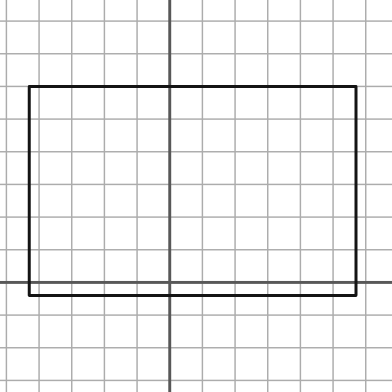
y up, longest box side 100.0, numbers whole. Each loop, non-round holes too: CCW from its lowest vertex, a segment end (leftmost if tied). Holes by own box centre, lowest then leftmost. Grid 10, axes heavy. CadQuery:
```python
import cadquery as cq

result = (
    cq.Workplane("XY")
    .moveTo(-43.0, -4.0)
    .lineTo(57.0, -4.0)
    .lineTo(57.0, 60.0)
    .lineTo(-43.0, 60.0)
    .close()
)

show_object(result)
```